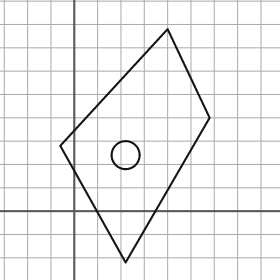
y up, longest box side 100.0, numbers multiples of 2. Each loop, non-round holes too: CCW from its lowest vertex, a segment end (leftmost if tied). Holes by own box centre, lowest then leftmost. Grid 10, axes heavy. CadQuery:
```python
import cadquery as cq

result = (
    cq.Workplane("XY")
    .moveTo(22.0, -22.0)
    .lineTo(58.0, 40.0)
    .lineTo(40.0, 78.0)
    .lineTo(-6.0, 28.0)
    .close()
    .moveTo(22.0, 24.0)
    .circle(6.0)
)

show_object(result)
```